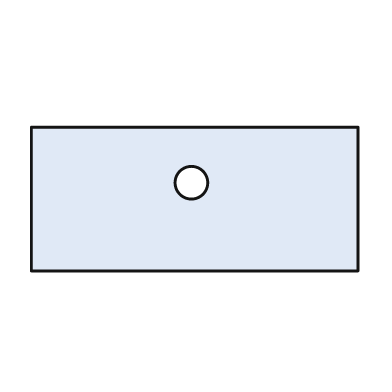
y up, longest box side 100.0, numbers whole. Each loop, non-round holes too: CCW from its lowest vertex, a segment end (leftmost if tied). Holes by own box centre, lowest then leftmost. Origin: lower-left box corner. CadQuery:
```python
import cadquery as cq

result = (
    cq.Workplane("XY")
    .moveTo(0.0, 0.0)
    .lineTo(100.0, 0.0)
    .lineTo(100.0, 44.0)
    .lineTo(0.0, 44.0)
    .close()
    .moveTo(49.0, 27.0)
    .circle(5.0)
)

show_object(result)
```